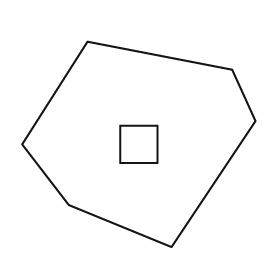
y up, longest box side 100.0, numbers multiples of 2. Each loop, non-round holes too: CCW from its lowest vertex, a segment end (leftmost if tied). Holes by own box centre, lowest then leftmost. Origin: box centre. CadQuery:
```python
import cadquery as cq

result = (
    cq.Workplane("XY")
    .moveTo(14.0, -44.0)
    .lineTo(50.0, 10.0)
    .lineTo(40.0, 32.0)
    .lineTo(-22.0, 44.0)
    .lineTo(-50.0, 0.0)
    .lineTo(-30.0, -26.0)
    .close()
    .moveTo(-8.0, -8.0)
    .lineTo(8.0, -8.0)
    .lineTo(8.0, 8.0)
    .lineTo(-8.0, 8.0)
    .close()
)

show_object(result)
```